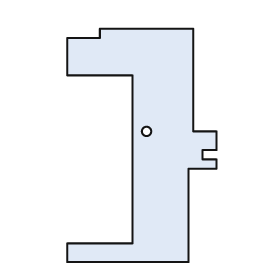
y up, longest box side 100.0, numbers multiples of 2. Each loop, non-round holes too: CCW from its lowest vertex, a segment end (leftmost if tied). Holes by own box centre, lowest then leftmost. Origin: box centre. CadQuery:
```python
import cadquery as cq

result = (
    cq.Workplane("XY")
    .moveTo(-32.0, -50.0)
    .lineTo(20.0, -50.0)
    .lineTo(20.0, -10.0)
    .lineTo(32.0, -10.0)
    .lineTo(32.0, -6.0)
    .lineTo(26.0, -6.0)
    .lineTo(26.0, -2.0)
    .lineTo(32.0, -2.0)
    .lineTo(32.0, 6.0)
    .lineTo(22.0, 6.0)
    .lineTo(22.0, 50.0)
    .lineTo(-18.0, 50.0)
    .lineTo(-18.0, 46.0)
    .lineTo(-32.0, 46.0)
    .lineTo(-32.0, 30.0)
    .lineTo(-4.0, 30.0)
    .lineTo(-4.0, -42.0)
    .lineTo(-32.0, -42.0)
    .close()
    .moveTo(2.0, 6.0)
    .circle(2.0)
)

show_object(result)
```